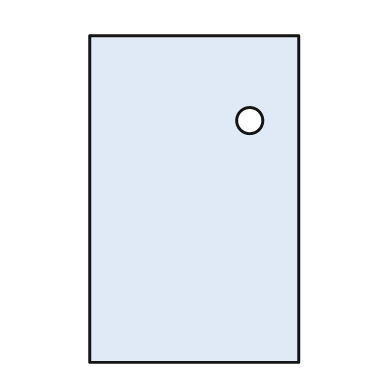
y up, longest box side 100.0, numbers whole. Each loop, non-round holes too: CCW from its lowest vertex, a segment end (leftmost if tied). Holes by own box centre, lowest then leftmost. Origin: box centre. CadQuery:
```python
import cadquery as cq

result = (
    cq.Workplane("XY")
    .moveTo(-32.0, -50.0)
    .lineTo(32.0, -50.0)
    .lineTo(32.0, 50.0)
    .lineTo(-32.0, 50.0)
    .close()
    .moveTo(17.0, 24.0)
    .circle(4.0)
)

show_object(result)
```